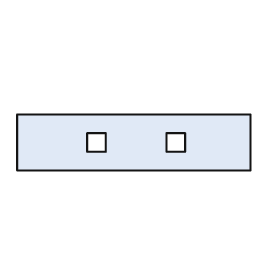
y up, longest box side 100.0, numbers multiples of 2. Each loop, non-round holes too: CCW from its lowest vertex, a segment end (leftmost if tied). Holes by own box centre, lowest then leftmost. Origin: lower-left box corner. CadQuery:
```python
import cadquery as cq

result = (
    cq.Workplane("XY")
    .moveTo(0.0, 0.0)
    .lineTo(100.0, 0.0)
    .lineTo(100.0, 24.0)
    .lineTo(0.0, 24.0)
    .close()
    .moveTo(30.0, 8.0)
    .lineTo(38.0, 8.0)
    .lineTo(38.0, 16.0)
    .lineTo(30.0, 16.0)
    .close()
    .moveTo(64.0, 8.0)
    .lineTo(72.0, 8.0)
    .lineTo(72.0, 16.0)
    .lineTo(64.0, 16.0)
    .close()
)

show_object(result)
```